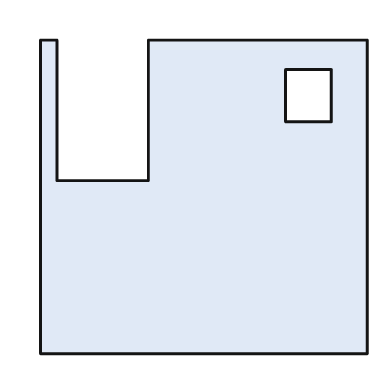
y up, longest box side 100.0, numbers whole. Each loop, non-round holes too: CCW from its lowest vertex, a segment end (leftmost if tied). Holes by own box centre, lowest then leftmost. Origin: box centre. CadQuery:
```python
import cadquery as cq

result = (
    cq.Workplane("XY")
    .moveTo(-50.0, -48.0)
    .lineTo(50.0, -48.0)
    .lineTo(50.0, 48.0)
    .lineTo(-17.0, 48.0)
    .lineTo(-17.0, 5.0)
    .lineTo(-45.0, 5.0)
    .lineTo(-45.0, 48.0)
    .lineTo(-50.0, 48.0)
    .close()
    .moveTo(25.0, 23.0)
    .lineTo(39.0, 23.0)
    .lineTo(39.0, 39.0)
    .lineTo(25.0, 39.0)
    .close()
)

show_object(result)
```